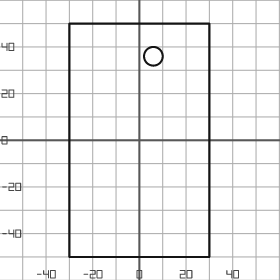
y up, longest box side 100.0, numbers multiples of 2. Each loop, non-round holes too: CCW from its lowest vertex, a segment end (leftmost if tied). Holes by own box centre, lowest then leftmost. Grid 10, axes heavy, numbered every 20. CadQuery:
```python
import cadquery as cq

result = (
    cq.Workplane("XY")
    .moveTo(-30.0, -50.0)
    .lineTo(30.0, -50.0)
    .lineTo(30.0, 50.0)
    .lineTo(-30.0, 50.0)
    .close()
    .moveTo(6.0, 36.0)
    .circle(4.0)
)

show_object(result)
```